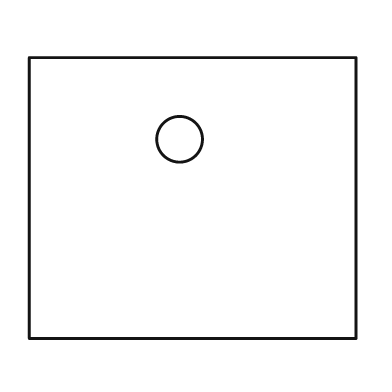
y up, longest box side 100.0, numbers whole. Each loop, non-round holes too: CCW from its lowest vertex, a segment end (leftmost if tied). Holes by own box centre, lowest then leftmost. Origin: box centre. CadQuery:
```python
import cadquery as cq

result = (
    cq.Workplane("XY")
    .moveTo(-50.0, -43.0)
    .lineTo(50.0, -43.0)
    .lineTo(50.0, 43.0)
    .lineTo(-50.0, 43.0)
    .close()
    .moveTo(-4.0, 18.0)
    .circle(7.0)
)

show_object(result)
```